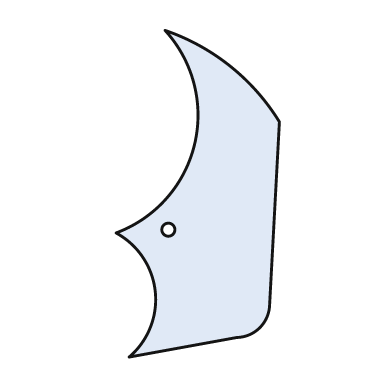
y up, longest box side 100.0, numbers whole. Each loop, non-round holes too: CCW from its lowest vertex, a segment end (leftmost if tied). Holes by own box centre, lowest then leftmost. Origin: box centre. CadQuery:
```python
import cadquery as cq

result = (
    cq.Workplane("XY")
    .moveTo(-21.0, -50.0)
    .lineTo(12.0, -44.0)
    .threePointArc((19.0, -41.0), (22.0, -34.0))
    .lineTo(25.0, 22.0)
    .threePointArc((10.0, 39.0), (-10.0, 50.0))
    .threePointArc((-1.0, 15.0), (-25.0, -12.0))
    .threePointArc((-13.0, -30.0), (-21.0, -50.0))
    .close()
    .moveTo(-9.0, -11.0)
    .circle(2.0)
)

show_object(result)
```